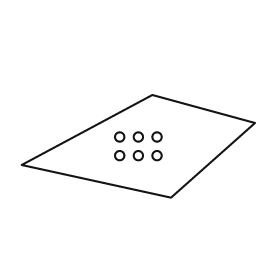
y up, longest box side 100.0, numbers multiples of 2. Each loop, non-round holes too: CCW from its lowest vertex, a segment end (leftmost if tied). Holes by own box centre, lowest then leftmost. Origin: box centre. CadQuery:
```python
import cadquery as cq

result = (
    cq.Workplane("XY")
    .moveTo(14.0, -22.0)
    .lineTo(50.0, 10.0)
    .lineTo(6.0, 22.0)
    .lineTo(-50.0, -8.0)
    .close()
    .moveTo(-8.0, -4.0)
    .circle(2.0)
    .moveTo(0.0, -4.0)
    .circle(2.0)
    .moveTo(8.0, -4.0)
    .circle(2.0)
    .moveTo(-8.0, 4.0)
    .circle(2.0)
    .moveTo(0.0, 4.0)
    .circle(2.0)
    .moveTo(8.0, 4.0)
    .circle(2.0)
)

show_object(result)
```